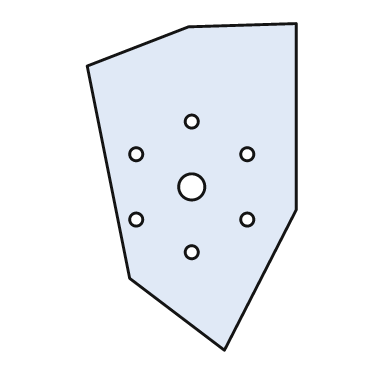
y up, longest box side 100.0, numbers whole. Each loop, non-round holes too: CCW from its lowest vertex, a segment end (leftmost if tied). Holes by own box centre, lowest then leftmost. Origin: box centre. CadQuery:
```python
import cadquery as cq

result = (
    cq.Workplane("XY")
    .moveTo(10.0, -50.0)
    .lineTo(32.0, -7.0)
    .lineTo(32.0, 50.0)
    .lineTo(-1.0, 49.0)
    .lineTo(-32.0, 37.0)
    .lineTo(-19.0, -28.0)
    .close()
    .moveTo(0.0, -20.0)
    .circle(2.0)
    .moveTo(-17.0, -10.0)
    .circle(2.0)
    .moveTo(17.0, -10.0)
    .circle(2.0)
    .moveTo(0.0, 0.0)
    .circle(4.0)
    .moveTo(-17.0, 10.0)
    .circle(2.0)
    .moveTo(17.0, 10.0)
    .circle(2.0)
    .moveTo(0.0, 20.0)
    .circle(2.0)
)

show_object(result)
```